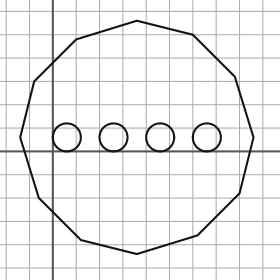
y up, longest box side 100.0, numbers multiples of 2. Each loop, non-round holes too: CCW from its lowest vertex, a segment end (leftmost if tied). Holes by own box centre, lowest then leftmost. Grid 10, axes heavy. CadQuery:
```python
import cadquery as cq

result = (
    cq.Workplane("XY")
    .moveTo(36.0, -44.0)
    .lineTo(62.0, -36.0)
    .lineTo(80.0, -18.0)
    .lineTo(86.0, 6.0)
    .lineTo(78.0, 32.0)
    .lineTo(60.0, 50.0)
    .lineTo(36.0, 56.0)
    .lineTo(10.0, 48.0)
    .lineTo(-8.0, 30.0)
    .lineTo(-14.0, 6.0)
    .lineTo(-6.0, -20.0)
    .lineTo(12.0, -38.0)
    .close()
    .moveTo(6.0, 6.0)
    .circle(6.0)
    .moveTo(26.0, 6.0)
    .circle(6.0)
    .moveTo(46.0, 6.0)
    .circle(6.0)
    .moveTo(66.0, 6.0)
    .circle(6.0)
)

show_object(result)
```